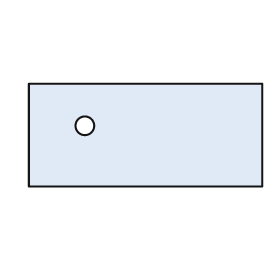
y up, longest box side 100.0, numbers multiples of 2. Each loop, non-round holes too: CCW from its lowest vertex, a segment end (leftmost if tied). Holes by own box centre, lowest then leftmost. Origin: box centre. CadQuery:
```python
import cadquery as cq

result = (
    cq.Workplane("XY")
    .moveTo(-50.0, -22.0)
    .lineTo(50.0, -22.0)
    .lineTo(50.0, 22.0)
    .lineTo(-50.0, 22.0)
    .close()
    .moveTo(-26.0, 4.0)
    .circle(4.0)
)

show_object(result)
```